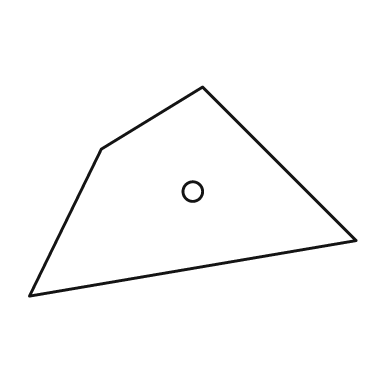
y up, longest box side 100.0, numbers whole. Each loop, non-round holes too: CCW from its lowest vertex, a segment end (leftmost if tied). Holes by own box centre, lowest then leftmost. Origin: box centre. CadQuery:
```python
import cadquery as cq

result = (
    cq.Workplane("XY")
    .moveTo(-50.0, -32.0)
    .lineTo(50.0, -15.0)
    .lineTo(3.0, 32.0)
    .lineTo(-28.0, 13.0)
    .close()
    .moveTo(0.0, 0.0)
    .circle(3.0)
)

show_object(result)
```